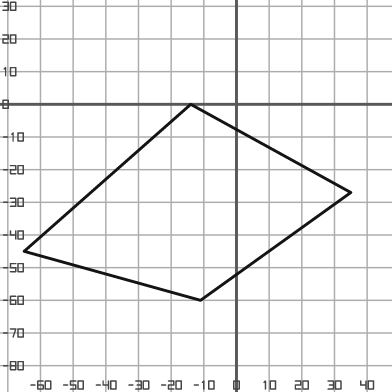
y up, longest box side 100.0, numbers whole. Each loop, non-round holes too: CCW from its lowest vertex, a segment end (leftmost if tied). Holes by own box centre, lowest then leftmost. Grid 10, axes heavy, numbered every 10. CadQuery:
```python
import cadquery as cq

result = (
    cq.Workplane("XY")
    .moveTo(-11.0, -60.0)
    .lineTo(35.0, -27.0)
    .lineTo(-14.0, 0.0)
    .lineTo(-65.0, -45.0)
    .close()
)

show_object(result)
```